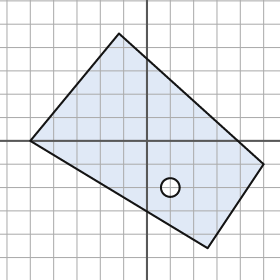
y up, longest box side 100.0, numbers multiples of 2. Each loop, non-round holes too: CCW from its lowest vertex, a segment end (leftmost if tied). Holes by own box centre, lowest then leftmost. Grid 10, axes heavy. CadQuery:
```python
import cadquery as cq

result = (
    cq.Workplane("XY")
    .moveTo(26.0, -46.0)
    .lineTo(50.0, -10.0)
    .lineTo(-12.0, 46.0)
    .lineTo(-50.0, 0.0)
    .close()
    .moveTo(10.0, -20.0)
    .circle(4.0)
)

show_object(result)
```